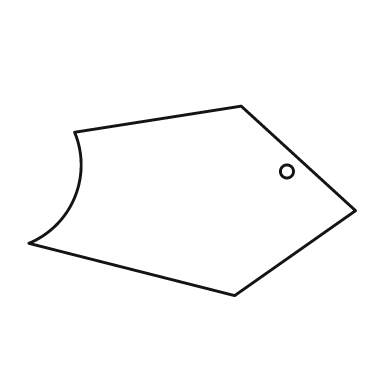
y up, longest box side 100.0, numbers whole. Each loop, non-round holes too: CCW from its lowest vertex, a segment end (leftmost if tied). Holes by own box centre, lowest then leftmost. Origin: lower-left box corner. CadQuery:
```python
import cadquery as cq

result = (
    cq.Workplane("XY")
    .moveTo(63.0, 0.0)
    .lineTo(100.0, 26.0)
    .lineTo(65.0, 58.0)
    .lineTo(14.0, 50.0)
    .threePointArc((14.0, 30.0), (0.0, 16.0))
    .close()
    .moveTo(79.0, 38.0)
    .circle(2.0)
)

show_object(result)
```